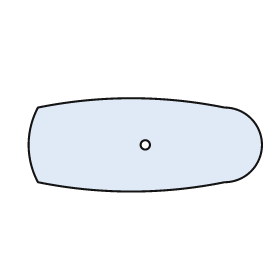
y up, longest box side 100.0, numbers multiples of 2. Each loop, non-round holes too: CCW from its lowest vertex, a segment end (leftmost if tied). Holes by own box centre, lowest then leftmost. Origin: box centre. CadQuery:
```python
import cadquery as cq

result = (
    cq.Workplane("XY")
    .moveTo(-46.0, -16.0)
    .threePointArc((-6.0, -20.0), (34.0, -16.0))
    .threePointArc((50.0, 0.0), (34.0, 16.0))
    .threePointArc((-6.0, 20.0), (-46.0, 16.0))
    .threePointArc((-50.0, 0.0), (-46.0, -16.0))
    .close()
    .moveTo(0.0, 0.0)
    .circle(2.0)
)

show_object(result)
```